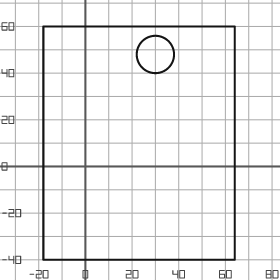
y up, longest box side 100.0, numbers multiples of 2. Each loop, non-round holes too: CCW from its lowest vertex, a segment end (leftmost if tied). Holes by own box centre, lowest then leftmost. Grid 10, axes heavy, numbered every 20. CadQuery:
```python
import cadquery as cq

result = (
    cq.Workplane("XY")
    .moveTo(-18.0, -40.0)
    .lineTo(64.0, -40.0)
    .lineTo(64.0, 60.0)
    .lineTo(-18.0, 60.0)
    .close()
    .moveTo(30.0, 48.0)
    .circle(8.0)
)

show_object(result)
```